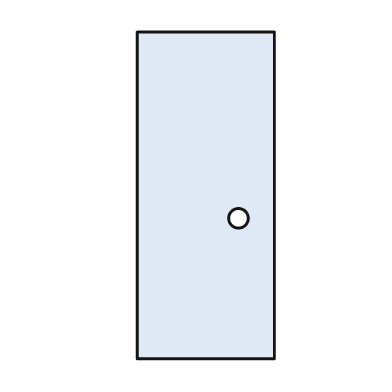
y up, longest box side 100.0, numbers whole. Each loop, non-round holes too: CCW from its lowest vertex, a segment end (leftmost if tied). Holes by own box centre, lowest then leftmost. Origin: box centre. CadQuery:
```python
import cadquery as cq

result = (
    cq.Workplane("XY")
    .moveTo(-21.0, -50.0)
    .lineTo(21.0, -50.0)
    .lineTo(21.0, 50.0)
    .lineTo(-21.0, 50.0)
    .close()
    .moveTo(10.0, -7.0)
    .circle(3.0)
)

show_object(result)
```